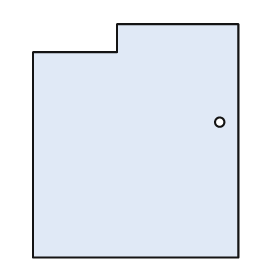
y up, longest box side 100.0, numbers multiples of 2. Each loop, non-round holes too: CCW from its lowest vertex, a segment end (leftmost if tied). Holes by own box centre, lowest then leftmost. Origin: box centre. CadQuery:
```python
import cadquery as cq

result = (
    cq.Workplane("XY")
    .moveTo(-44.0, -50.0)
    .lineTo(44.0, -50.0)
    .lineTo(44.0, 50.0)
    .lineTo(-8.0, 50.0)
    .lineTo(-8.0, 38.0)
    .lineTo(-44.0, 38.0)
    .close()
    .moveTo(36.0, 8.0)
    .circle(2.0)
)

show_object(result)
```